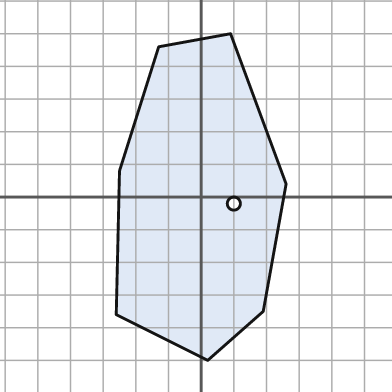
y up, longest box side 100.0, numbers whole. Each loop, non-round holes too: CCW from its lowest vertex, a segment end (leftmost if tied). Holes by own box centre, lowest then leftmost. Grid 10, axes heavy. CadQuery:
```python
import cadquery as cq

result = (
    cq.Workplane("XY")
    .moveTo(2.0, -50.0)
    .lineTo(19.0, -35.0)
    .lineTo(26.0, 4.0)
    .lineTo(9.0, 50.0)
    .lineTo(-13.0, 46.0)
    .lineTo(-25.0, 8.0)
    .lineTo(-26.0, -36.0)
    .close()
    .moveTo(10.0, -2.0)
    .circle(2.0)
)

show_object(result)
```